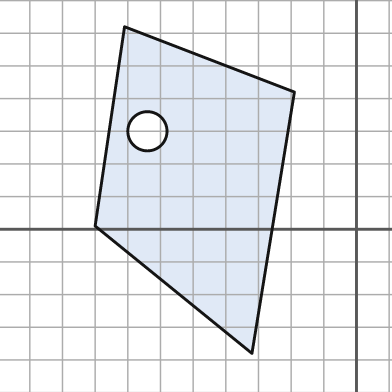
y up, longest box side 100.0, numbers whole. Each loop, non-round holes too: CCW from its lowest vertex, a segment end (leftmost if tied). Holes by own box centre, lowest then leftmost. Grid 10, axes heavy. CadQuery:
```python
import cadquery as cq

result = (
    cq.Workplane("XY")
    .moveTo(-32.0, -38.0)
    .lineTo(-19.0, 42.0)
    .lineTo(-71.0, 62.0)
    .lineTo(-80.0, 1.0)
    .close()
    .moveTo(-64.0, 30.0)
    .circle(6.0)
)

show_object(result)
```